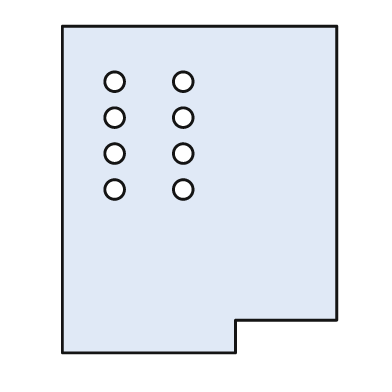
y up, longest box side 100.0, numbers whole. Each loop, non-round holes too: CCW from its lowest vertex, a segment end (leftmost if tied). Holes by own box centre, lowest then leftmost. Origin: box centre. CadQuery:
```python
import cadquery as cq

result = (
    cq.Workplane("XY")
    .moveTo(-42.0, -50.0)
    .lineTo(11.0, -50.0)
    .lineTo(11.0, -40.0)
    .lineTo(42.0, -40.0)
    .lineTo(42.0, 50.0)
    .lineTo(-42.0, 50.0)
    .close()
    .moveTo(-26.0, 0.0)
    .circle(3.0)
    .moveTo(-5.0, 0.0)
    .circle(3.0)
    .moveTo(-26.0, 11.0)
    .circle(3.0)
    .moveTo(-5.0, 11.0)
    .circle(3.0)
    .moveTo(-26.0, 22.0)
    .circle(3.0)
    .moveTo(-5.0, 22.0)
    .circle(3.0)
    .moveTo(-26.0, 33.0)
    .circle(3.0)
    .moveTo(-5.0, 33.0)
    .circle(3.0)
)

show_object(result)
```